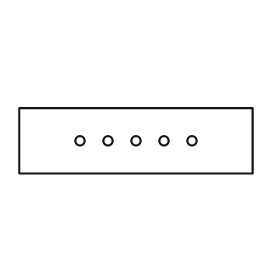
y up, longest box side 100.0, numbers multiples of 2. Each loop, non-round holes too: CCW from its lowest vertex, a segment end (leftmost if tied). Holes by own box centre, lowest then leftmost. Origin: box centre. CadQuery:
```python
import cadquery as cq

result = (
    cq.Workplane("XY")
    .moveTo(-50.0, -14.0)
    .lineTo(50.0, -14.0)
    .lineTo(50.0, 14.0)
    .lineTo(-50.0, 14.0)
    .close()
    .moveTo(-24.0, 0.0)
    .circle(2.0)
    .moveTo(-12.0, 0.0)
    .circle(2.0)
    .moveTo(0.0, 0.0)
    .circle(2.0)
    .moveTo(12.0, 0.0)
    .circle(2.0)
    .moveTo(24.0, 0.0)
    .circle(2.0)
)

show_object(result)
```